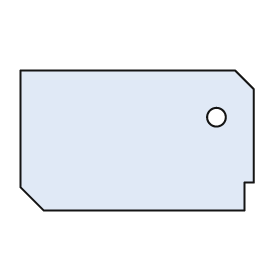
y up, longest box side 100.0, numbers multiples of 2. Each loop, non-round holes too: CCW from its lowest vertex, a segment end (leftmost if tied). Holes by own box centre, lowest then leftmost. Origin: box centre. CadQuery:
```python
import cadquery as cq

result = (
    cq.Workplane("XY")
    .moveTo(-40.0, -30.0)
    .lineTo(46.0, -30.0)
    .lineTo(46.0, -18.0)
    .lineTo(50.0, -18.0)
    .lineTo(50.0, 22.0)
    .lineTo(42.0, 30.0)
    .lineTo(-50.0, 30.0)
    .lineTo(-50.0, -20.0)
    .close()
    .moveTo(34.0, 10.0)
    .circle(4.0)
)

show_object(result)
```